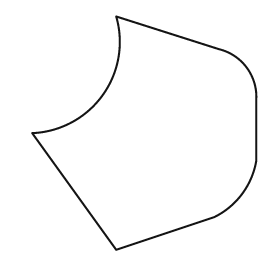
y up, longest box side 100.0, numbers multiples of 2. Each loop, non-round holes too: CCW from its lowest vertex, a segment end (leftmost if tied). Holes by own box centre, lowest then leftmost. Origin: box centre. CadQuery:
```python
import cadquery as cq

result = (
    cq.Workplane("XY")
    .moveTo(-12.0, -50.0)
    .lineTo(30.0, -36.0)
    .threePointArc((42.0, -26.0), (48.0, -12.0))
    .lineTo(48.0, 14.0)
    .threePointArc((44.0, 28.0), (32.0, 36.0))
    .lineTo(-12.0, 50.0)
    .threePointArc((-18.0, 16.0), (-48.0, 0.0))
    .close()
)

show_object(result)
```